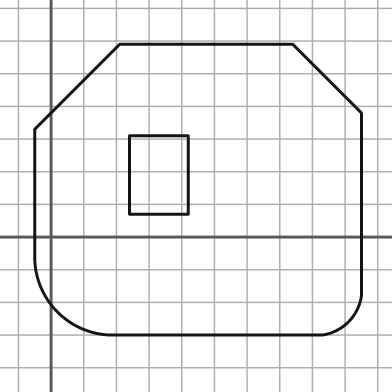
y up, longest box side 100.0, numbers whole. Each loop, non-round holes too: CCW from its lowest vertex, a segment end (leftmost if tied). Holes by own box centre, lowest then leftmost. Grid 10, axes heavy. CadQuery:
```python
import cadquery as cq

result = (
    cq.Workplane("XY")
    .moveTo(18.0, -30.0)
    .lineTo(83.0, -30.0)
    .threePointArc((91.0, -26.0), (95.0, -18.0))
    .lineTo(95.0, 38.0)
    .lineTo(74.0, 59.0)
    .lineTo(21.0, 59.0)
    .lineTo(-5.0, 33.0)
    .lineTo(-5.0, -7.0)
    .threePointArc((2.0, -23.0), (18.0, -30.0))
    .close()
    .moveTo(24.0, 7.0)
    .lineTo(42.0, 7.0)
    .lineTo(42.0, 31.0)
    .lineTo(24.0, 31.0)
    .close()
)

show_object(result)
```